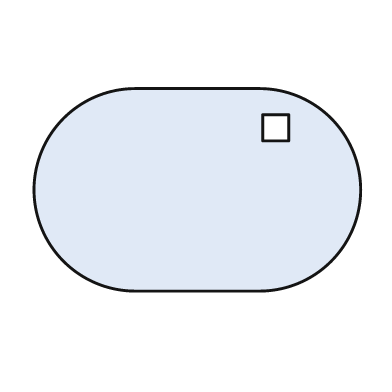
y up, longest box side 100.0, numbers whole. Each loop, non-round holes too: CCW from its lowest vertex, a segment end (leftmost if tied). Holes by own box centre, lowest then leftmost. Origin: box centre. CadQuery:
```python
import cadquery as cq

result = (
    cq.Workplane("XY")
    .moveTo(-19.0, -31.0)
    .lineTo(19.0, -31.0)
    .threePointArc((50.0, 0.0), (19.0, 31.0))
    .lineTo(-19.0, 31.0)
    .threePointArc((-50.0, 0.0), (-19.0, -31.0))
    .close()
    .moveTo(20.0, 15.0)
    .lineTo(28.0, 15.0)
    .lineTo(28.0, 23.0)
    .lineTo(20.0, 23.0)
    .close()
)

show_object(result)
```